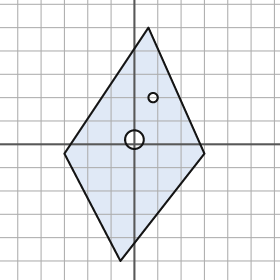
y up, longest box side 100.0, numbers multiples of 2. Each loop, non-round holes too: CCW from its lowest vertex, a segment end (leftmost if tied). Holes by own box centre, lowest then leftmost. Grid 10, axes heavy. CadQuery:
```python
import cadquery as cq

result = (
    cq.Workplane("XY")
    .moveTo(-6.0, -50.0)
    .lineTo(30.0, -4.0)
    .lineTo(6.0, 50.0)
    .lineTo(-30.0, -4.0)
    .close()
    .moveTo(0.0, 2.0)
    .circle(4.0)
    .moveTo(8.0, 20.0)
    .circle(2.0)
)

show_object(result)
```